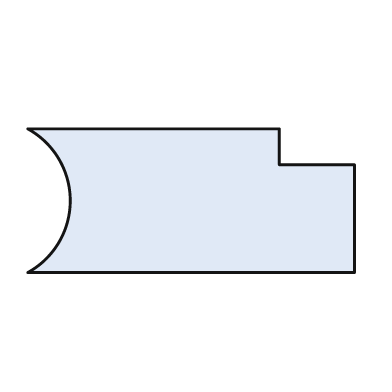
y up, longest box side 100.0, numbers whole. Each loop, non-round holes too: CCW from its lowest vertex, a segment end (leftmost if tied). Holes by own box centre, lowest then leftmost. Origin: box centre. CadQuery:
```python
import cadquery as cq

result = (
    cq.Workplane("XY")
    .moveTo(-50.0, -22.0)
    .lineTo(50.0, -22.0)
    .lineTo(50.0, 11.0)
    .lineTo(27.0, 11.0)
    .lineTo(27.0, 22.0)
    .lineTo(-50.0, 22.0)
    .threePointArc((-37.0, 0.0), (-50.0, -22.0))
    .close()
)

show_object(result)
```